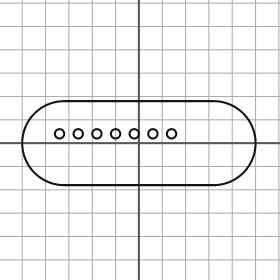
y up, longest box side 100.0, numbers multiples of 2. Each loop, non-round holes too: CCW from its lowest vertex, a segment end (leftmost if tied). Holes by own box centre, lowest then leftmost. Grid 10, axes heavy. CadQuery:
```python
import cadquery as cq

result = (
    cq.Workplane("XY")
    .moveTo(-32.0, -18.0)
    .lineTo(32.0, -18.0)
    .threePointArc((50.0, 0.0), (32.0, 18.0))
    .lineTo(-32.0, 18.0)
    .threePointArc((-50.0, 0.0), (-32.0, -18.0))
    .close()
    .moveTo(-34.0, 4.0)
    .circle(2.0)
    .moveTo(-26.0, 4.0)
    .circle(2.0)
    .moveTo(-18.0, 4.0)
    .circle(2.0)
    .moveTo(-10.0, 4.0)
    .circle(2.0)
    .moveTo(-2.0, 4.0)
    .circle(2.0)
    .moveTo(6.0, 4.0)
    .circle(2.0)
    .moveTo(14.0, 4.0)
    .circle(2.0)
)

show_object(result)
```